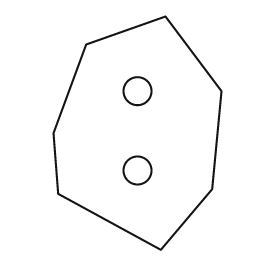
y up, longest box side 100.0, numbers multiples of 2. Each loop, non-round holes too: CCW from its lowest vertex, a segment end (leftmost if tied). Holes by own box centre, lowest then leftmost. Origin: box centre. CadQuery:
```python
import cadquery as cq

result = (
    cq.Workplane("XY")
    .moveTo(10.0, -50.0)
    .lineTo(32.0, -24.0)
    .lineTo(36.0, 18.0)
    .lineTo(12.0, 50.0)
    .lineTo(-22.0, 38.0)
    .lineTo(-36.0, 0.0)
    .lineTo(-34.0, -26.0)
    .close()
    .moveTo(0.0, -16.0)
    .circle(6.0)
    .moveTo(0.0, 18.0)
    .circle(6.0)
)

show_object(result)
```